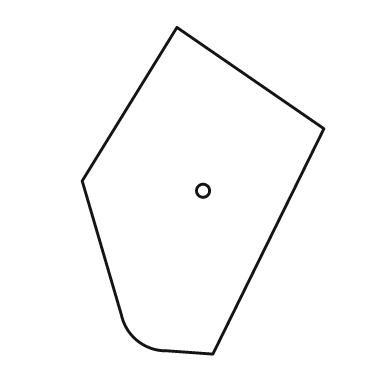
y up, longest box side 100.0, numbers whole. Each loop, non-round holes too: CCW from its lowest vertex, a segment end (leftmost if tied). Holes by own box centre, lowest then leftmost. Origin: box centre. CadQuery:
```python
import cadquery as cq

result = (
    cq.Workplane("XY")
    .moveTo(3.0, -50.0)
    .lineTo(37.0, 19.0)
    .lineTo(-8.0, 50.0)
    .lineTo(-37.0, 3.0)
    .lineTo(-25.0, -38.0)
    .threePointArc((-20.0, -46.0), (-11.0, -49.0))
    .close()
    .moveTo(0.0, 0.0)
    .circle(2.0)
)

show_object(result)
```